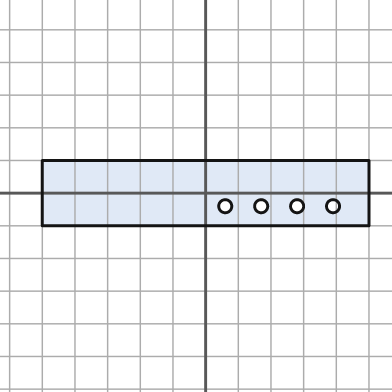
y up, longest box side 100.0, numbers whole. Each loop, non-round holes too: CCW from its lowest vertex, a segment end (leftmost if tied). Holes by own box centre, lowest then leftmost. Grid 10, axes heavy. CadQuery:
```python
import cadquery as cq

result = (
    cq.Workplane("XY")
    .moveTo(-50.0, -10.0)
    .lineTo(50.0, -10.0)
    .lineTo(50.0, 10.0)
    .lineTo(-50.0, 10.0)
    .close()
    .moveTo(6.0, -4.0)
    .circle(2.0)
    .moveTo(17.0, -4.0)
    .circle(2.0)
    .moveTo(28.0, -4.0)
    .circle(2.0)
    .moveTo(39.0, -4.0)
    .circle(2.0)
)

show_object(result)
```